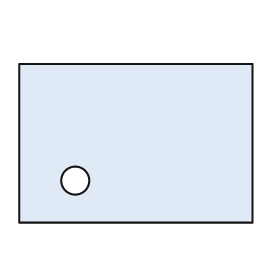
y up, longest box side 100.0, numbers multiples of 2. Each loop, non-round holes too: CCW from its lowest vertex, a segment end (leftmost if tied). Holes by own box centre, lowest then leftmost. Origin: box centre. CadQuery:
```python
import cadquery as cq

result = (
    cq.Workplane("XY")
    .moveTo(-50.0, -34.0)
    .lineTo(50.0, -34.0)
    .lineTo(50.0, 34.0)
    .lineTo(-50.0, 34.0)
    .close()
    .moveTo(-26.0, -16.0)
    .circle(6.0)
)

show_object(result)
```